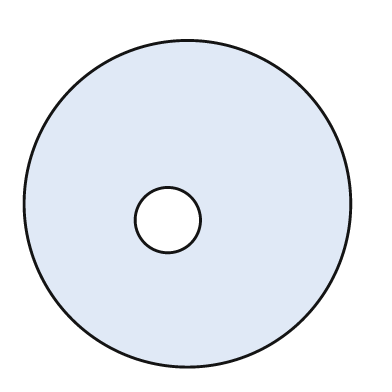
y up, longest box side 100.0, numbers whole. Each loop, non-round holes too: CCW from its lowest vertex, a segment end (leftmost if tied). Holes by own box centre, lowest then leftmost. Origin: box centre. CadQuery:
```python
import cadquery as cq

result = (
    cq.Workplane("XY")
    .moveTo(0.0, 0.0)
    .circle(50.0)
    .moveTo(-6.0, -5.0)
    .circle(10.0)
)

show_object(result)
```